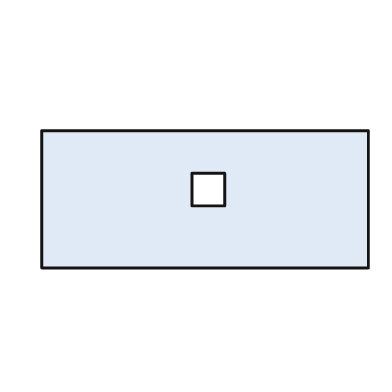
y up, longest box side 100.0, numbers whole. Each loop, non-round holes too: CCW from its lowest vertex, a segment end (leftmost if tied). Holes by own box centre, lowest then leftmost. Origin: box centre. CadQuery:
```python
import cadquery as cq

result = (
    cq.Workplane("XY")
    .moveTo(-50.0, -21.0)
    .lineTo(50.0, -21.0)
    .lineTo(50.0, 21.0)
    .lineTo(-50.0, 21.0)
    .close()
    .moveTo(-4.0, -2.0)
    .lineTo(6.0, -2.0)
    .lineTo(6.0, 8.0)
    .lineTo(-4.0, 8.0)
    .close()
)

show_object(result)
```